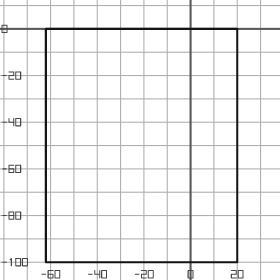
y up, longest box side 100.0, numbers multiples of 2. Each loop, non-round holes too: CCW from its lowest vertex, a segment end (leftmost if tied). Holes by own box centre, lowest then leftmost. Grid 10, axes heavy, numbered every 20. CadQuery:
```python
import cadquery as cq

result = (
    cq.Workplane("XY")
    .moveTo(-62.0, -100.0)
    .lineTo(20.0, -100.0)
    .lineTo(20.0, 0.0)
    .lineTo(-62.0, 0.0)
    .close()
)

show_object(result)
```